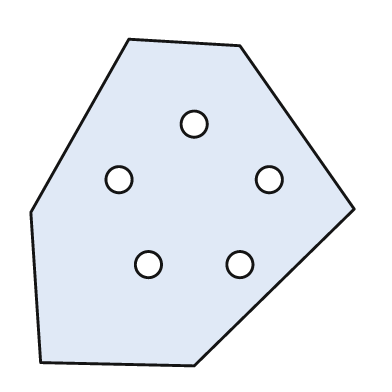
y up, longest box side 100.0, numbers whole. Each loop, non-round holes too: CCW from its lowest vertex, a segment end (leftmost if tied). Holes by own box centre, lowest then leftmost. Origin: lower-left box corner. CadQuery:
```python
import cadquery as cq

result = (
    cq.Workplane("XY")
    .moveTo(50.0, 0.0)
    .lineTo(99.0, 48.0)
    .lineTo(64.0, 98.0)
    .lineTo(30.0, 100.0)
    .lineTo(0.0, 47.0)
    .lineTo(3.0, 1.0)
    .close()
    .moveTo(36.0, 31.0)
    .circle(4.0)
    .moveTo(64.0, 31.0)
    .circle(4.0)
    .moveTo(27.0, 57.0)
    .circle(4.0)
    .moveTo(73.0, 57.0)
    .circle(4.0)
    .moveTo(50.0, 74.0)
    .circle(4.0)
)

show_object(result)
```